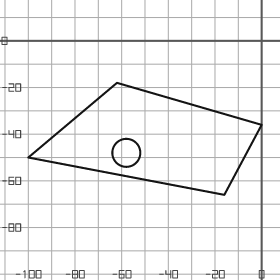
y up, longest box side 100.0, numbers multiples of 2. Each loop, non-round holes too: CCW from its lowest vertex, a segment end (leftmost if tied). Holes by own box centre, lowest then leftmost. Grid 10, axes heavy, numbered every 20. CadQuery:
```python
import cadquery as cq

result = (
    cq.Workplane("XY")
    .moveTo(-16.0, -66.0)
    .lineTo(0.0, -36.0)
    .lineTo(-62.0, -18.0)
    .lineTo(-100.0, -50.0)
    .close()
    .moveTo(-58.0, -48.0)
    .circle(6.0)
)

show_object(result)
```